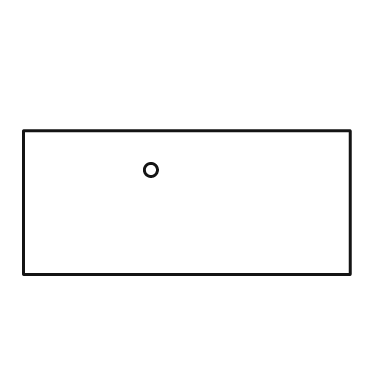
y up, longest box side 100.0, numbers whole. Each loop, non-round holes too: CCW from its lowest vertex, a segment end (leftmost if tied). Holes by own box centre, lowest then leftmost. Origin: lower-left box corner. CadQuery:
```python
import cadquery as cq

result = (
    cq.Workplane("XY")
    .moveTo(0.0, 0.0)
    .lineTo(100.0, 0.0)
    .lineTo(100.0, 44.0)
    .lineTo(0.0, 44.0)
    .close()
    .moveTo(39.0, 32.0)
    .circle(2.0)
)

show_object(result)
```